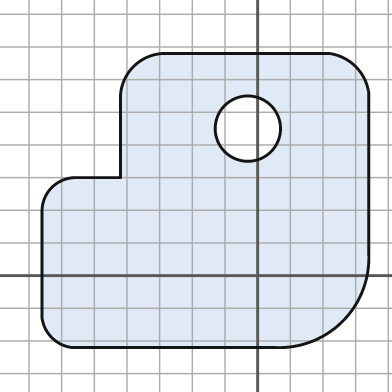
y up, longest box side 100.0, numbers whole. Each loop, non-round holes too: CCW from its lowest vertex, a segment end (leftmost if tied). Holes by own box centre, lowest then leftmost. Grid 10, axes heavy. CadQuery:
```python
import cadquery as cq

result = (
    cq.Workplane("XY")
    .moveTo(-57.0, -22.0)
    .lineTo(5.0, -22.0)
    .threePointArc((26.0, -14.0), (34.0, 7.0))
    .lineTo(34.0, 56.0)
    .threePointArc((30.0, 64.0), (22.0, 68.0))
    .lineTo(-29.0, 68.0)
    .threePointArc((-38.0, 64.0), (-42.0, 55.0))
    .lineTo(-42.0, 30.0)
    .lineTo(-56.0, 30.0)
    .threePointArc((-63.0, 27.0), (-66.0, 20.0))
    .lineTo(-66.0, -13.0)
    .threePointArc((-63.0, -19.0), (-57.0, -22.0))
    .close()
    .moveTo(-3.0, 45.0)
    .circle(10.0)
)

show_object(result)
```